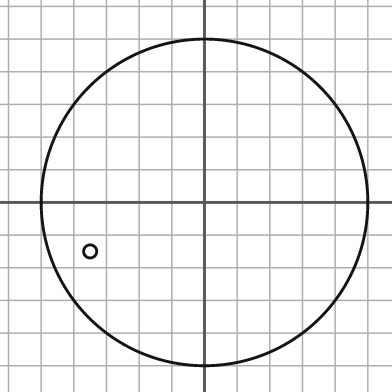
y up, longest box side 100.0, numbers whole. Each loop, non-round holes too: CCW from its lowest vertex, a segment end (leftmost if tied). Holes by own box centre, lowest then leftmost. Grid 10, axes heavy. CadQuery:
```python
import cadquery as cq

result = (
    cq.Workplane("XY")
    .moveTo(0.0, 0.0)
    .circle(50.0)
    .moveTo(-35.0, -15.0)
    .circle(2.0)
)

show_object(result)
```